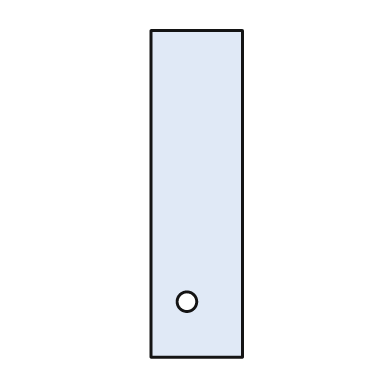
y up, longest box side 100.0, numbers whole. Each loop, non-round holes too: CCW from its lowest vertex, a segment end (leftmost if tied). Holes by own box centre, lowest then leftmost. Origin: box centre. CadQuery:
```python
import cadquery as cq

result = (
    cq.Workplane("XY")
    .moveTo(-14.0, -50.0)
    .lineTo(14.0, -50.0)
    .lineTo(14.0, 50.0)
    .lineTo(-14.0, 50.0)
    .close()
    .moveTo(-3.0, -33.0)
    .circle(3.0)
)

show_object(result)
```